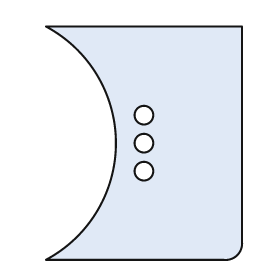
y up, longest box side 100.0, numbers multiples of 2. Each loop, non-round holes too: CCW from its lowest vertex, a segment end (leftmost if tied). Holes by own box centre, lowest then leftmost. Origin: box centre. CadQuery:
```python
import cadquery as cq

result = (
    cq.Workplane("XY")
    .moveTo(-42.0, -50.0)
    .lineTo(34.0, -50.0)
    .threePointArc((40.0, -48.0), (42.0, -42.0))
    .lineTo(42.0, 50.0)
    .lineTo(-42.0, 50.0)
    .threePointArc((-12.0, 0.0), (-42.0, -50.0))
    .close()
    .moveTo(0.0, -12.0)
    .circle(4.0)
    .moveTo(0.0, 0.0)
    .circle(4.0)
    .moveTo(0.0, 12.0)
    .circle(4.0)
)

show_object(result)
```